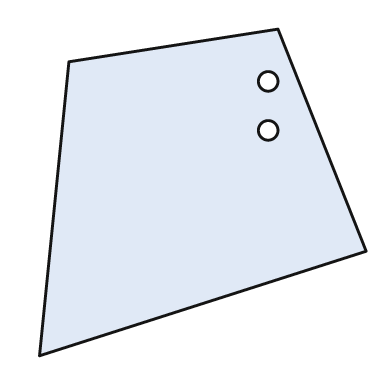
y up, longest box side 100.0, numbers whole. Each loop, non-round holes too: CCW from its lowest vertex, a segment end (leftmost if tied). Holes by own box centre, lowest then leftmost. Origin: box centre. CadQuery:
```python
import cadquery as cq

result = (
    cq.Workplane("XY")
    .moveTo(-50.0, -50.0)
    .lineTo(50.0, -18.0)
    .lineTo(23.0, 50.0)
    .lineTo(-41.0, 40.0)
    .close()
    .moveTo(20.0, 19.0)
    .circle(3.0)
    .moveTo(20.0, 34.0)
    .circle(3.0)
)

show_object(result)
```